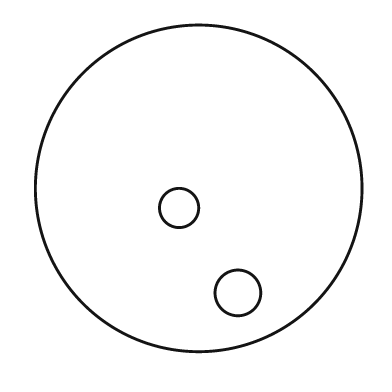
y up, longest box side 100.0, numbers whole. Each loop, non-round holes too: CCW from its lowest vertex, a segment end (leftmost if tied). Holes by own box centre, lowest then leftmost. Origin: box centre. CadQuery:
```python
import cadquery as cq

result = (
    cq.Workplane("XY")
    .moveTo(0.0, 0.0)
    .circle(50.0)
    .moveTo(12.0, -32.0)
    .circle(7.0)
    .moveTo(-6.0, -6.0)
    .circle(6.0)
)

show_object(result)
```